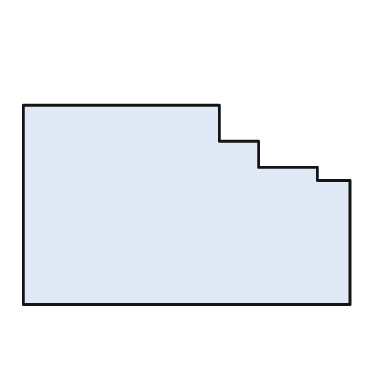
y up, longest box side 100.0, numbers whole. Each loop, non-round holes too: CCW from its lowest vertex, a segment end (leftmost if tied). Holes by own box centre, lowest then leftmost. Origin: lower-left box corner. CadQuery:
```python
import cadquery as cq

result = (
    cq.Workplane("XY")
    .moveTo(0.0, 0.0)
    .lineTo(100.0, 0.0)
    .lineTo(100.0, 38.0)
    .lineTo(90.0, 38.0)
    .lineTo(90.0, 42.0)
    .lineTo(72.0, 42.0)
    .lineTo(72.0, 50.0)
    .lineTo(60.0, 50.0)
    .lineTo(60.0, 61.0)
    .lineTo(0.0, 61.0)
    .close()
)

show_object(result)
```